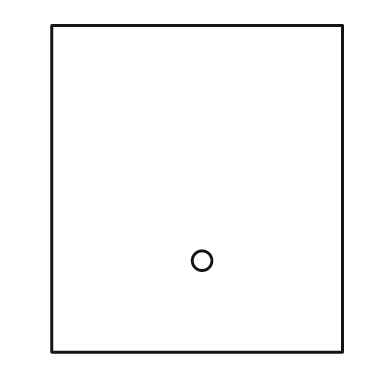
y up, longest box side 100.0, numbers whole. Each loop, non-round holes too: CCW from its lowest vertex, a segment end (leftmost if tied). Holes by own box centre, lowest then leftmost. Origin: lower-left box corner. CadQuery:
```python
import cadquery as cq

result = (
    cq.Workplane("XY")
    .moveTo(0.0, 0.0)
    .lineTo(89.0, 0.0)
    .lineTo(89.0, 100.0)
    .lineTo(0.0, 100.0)
    .close()
    .moveTo(46.0, 28.0)
    .circle(3.0)
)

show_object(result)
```